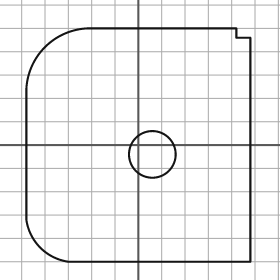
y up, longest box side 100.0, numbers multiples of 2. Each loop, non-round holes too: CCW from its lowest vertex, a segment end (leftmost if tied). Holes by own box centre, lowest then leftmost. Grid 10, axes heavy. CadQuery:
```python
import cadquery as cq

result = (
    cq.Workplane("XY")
    .moveTo(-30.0, -50.0)
    .lineTo(48.0, -50.0)
    .lineTo(48.0, 46.0)
    .lineTo(42.0, 46.0)
    .lineTo(42.0, 50.0)
    .lineTo(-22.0, 50.0)
    .threePointArc((-40.0, 42.0), (-48.0, 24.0))
    .lineTo(-48.0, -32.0)
    .threePointArc((-42.0, -44.0), (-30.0, -50.0))
    .close()
    .moveTo(6.0, -4.0)
    .circle(10.0)
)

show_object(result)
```